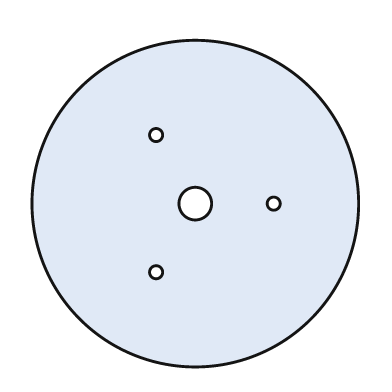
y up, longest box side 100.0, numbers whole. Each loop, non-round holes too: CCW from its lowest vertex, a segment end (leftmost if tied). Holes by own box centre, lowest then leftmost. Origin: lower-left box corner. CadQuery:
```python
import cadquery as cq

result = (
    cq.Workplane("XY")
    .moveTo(50.0, 50.0)
    .circle(50.0)
    .moveTo(38.0, 29.0)
    .circle(2.0)
    .moveTo(50.0, 50.0)
    .circle(5.0)
    .moveTo(74.0, 50.0)
    .circle(2.0)
    .moveTo(38.0, 71.0)
    .circle(2.0)
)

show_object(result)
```